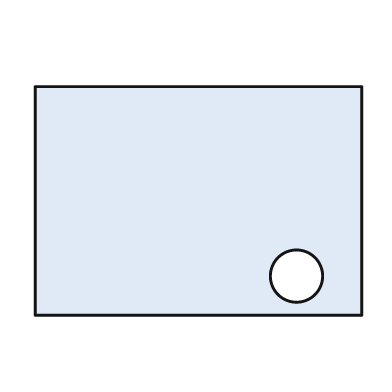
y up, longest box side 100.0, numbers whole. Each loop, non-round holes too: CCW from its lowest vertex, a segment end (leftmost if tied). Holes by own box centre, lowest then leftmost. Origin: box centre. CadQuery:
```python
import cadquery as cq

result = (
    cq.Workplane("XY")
    .moveTo(-50.0, -35.0)
    .lineTo(50.0, -35.0)
    .lineTo(50.0, 35.0)
    .lineTo(-50.0, 35.0)
    .close()
    .moveTo(30.0, -23.0)
    .circle(8.0)
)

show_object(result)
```